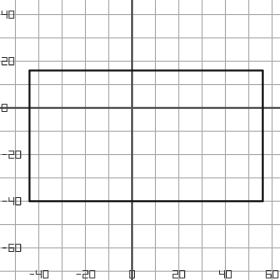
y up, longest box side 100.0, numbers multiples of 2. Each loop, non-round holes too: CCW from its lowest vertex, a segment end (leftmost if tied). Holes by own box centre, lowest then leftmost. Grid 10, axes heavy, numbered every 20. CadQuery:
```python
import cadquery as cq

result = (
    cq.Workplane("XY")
    .moveTo(-44.0, -40.0)
    .lineTo(56.0, -40.0)
    .lineTo(56.0, 16.0)
    .lineTo(-44.0, 16.0)
    .close()
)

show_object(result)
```